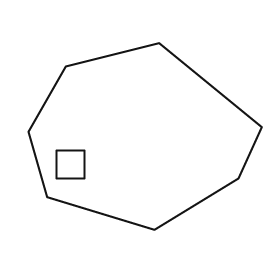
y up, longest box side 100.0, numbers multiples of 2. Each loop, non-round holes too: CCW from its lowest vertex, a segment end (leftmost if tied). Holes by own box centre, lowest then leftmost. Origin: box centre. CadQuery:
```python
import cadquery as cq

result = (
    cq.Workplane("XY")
    .moveTo(4.0, -40.0)
    .lineTo(40.0, -18.0)
    .lineTo(50.0, 4.0)
    .lineTo(6.0, 40.0)
    .lineTo(-34.0, 30.0)
    .lineTo(-50.0, 2.0)
    .lineTo(-42.0, -26.0)
    .close()
    .moveTo(-38.0, -18.0)
    .lineTo(-26.0, -18.0)
    .lineTo(-26.0, -6.0)
    .lineTo(-38.0, -6.0)
    .close()
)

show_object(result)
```